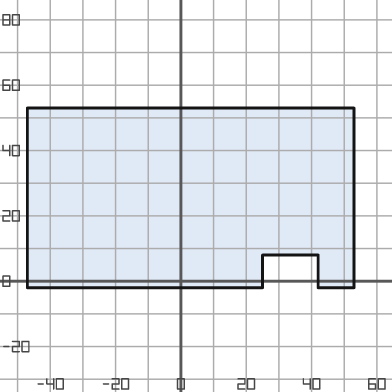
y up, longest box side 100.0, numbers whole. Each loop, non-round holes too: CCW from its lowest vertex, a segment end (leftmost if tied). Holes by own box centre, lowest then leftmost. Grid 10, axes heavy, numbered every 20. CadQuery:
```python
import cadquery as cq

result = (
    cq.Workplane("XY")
    .moveTo(-47.0, -2.0)
    .lineTo(25.0, -2.0)
    .lineTo(25.0, 8.0)
    .lineTo(42.0, 8.0)
    .lineTo(42.0, -2.0)
    .lineTo(53.0, -2.0)
    .lineTo(53.0, 53.0)
    .lineTo(-47.0, 53.0)
    .close()
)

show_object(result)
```